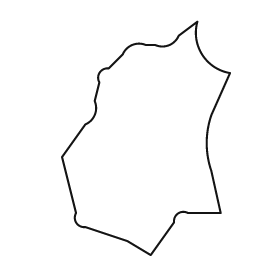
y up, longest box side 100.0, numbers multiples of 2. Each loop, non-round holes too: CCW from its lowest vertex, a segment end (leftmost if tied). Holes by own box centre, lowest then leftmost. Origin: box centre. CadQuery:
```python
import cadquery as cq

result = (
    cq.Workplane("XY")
    .moveTo(2.0, -50.0)
    .lineTo(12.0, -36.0)
    .threePointArc((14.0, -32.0), (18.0, -32.0))
    .lineTo(32.0, -32.0)
    .lineTo(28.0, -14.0)
    .threePointArc((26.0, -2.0), (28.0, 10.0))
    .lineTo(36.0, 28.0)
    .threePointArc((24.0, 36.0), (22.0, 50.0))
    .lineTo(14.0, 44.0)
    .threePointArc((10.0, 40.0), (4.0, 40.0))
    .lineTo(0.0, 40.0)
    .threePointArc((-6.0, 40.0), (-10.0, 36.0))
    .lineTo(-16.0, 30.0)
    .threePointArc((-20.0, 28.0), (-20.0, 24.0))
    .lineTo(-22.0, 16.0)
    .threePointArc((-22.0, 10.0), (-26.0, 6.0))
    .lineTo(-36.0, -8.0)
    .lineTo(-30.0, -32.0)
    .threePointArc((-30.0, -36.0), (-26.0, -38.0))
    .lineTo(-8.0, -44.0)
    .close()
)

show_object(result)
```